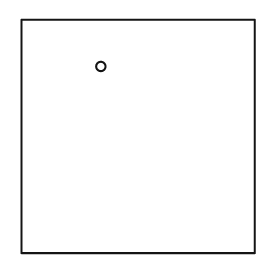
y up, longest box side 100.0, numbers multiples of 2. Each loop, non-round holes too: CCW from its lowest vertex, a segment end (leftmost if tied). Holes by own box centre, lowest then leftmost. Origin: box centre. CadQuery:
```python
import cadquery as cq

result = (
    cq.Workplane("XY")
    .moveTo(-50.0, -50.0)
    .lineTo(50.0, -50.0)
    .lineTo(50.0, 50.0)
    .lineTo(-50.0, 50.0)
    .close()
    .moveTo(-16.0, 30.0)
    .circle(2.0)
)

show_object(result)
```